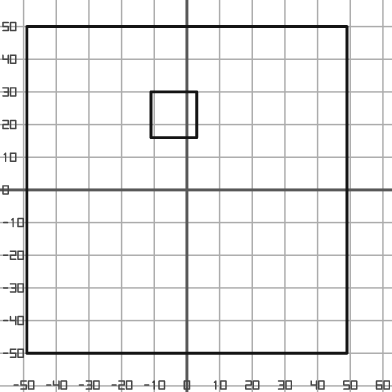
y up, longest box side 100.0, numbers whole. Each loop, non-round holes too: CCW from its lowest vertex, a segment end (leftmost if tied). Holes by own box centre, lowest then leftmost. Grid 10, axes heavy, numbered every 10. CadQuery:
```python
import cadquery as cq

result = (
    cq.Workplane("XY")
    .moveTo(-49.0, -50.0)
    .lineTo(49.0, -50.0)
    .lineTo(49.0, 50.0)
    .lineTo(-49.0, 50.0)
    .close()
    .moveTo(-11.0, 16.0)
    .lineTo(3.0, 16.0)
    .lineTo(3.0, 30.0)
    .lineTo(-11.0, 30.0)
    .close()
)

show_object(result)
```